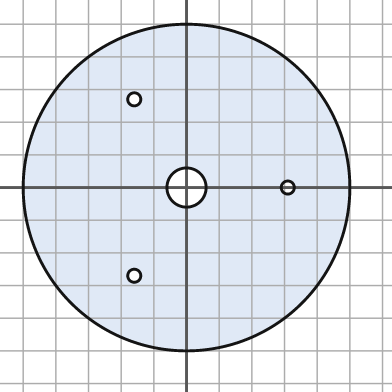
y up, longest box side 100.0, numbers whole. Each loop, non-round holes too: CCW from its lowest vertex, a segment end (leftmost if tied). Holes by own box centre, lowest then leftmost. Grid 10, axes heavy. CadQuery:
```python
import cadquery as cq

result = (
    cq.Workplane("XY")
    .moveTo(0.0, 0.0)
    .circle(50.0)
    .moveTo(-16.0, -27.0)
    .circle(2.0)
    .moveTo(0.0, 0.0)
    .circle(6.0)
    .moveTo(31.0, 0.0)
    .circle(2.0)
    .moveTo(-16.0, 27.0)
    .circle(2.0)
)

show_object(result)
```